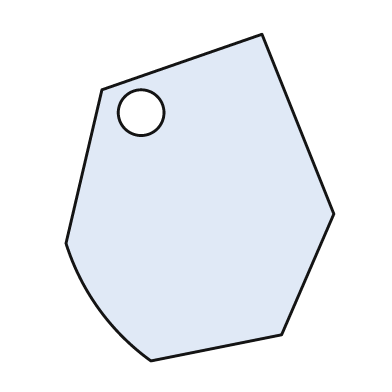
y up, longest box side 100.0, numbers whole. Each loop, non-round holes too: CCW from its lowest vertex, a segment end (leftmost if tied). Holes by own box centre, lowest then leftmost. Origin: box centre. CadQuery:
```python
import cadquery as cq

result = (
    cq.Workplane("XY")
    .moveTo(-15.0, -50.0)
    .lineTo(25.0, -42.0)
    .lineTo(41.0, -5.0)
    .lineTo(19.0, 50.0)
    .lineTo(-30.0, 33.0)
    .lineTo(-41.0, -14.0)
    .threePointArc((-31.0, -34.0), (-15.0, -50.0))
    .close()
    .moveTo(-18.0, 26.0)
    .circle(7.0)
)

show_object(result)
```